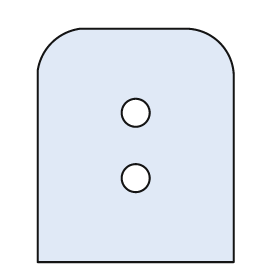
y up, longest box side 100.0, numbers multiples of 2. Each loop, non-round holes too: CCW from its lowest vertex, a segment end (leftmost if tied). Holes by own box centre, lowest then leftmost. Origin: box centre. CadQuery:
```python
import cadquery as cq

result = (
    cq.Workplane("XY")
    .moveTo(-42.0, -50.0)
    .lineTo(42.0, -50.0)
    .lineTo(42.0, 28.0)
    .threePointArc((36.0, 44.0), (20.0, 50.0))
    .lineTo(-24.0, 50.0)
    .threePointArc((-36.0, 44.0), (-42.0, 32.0))
    .close()
    .moveTo(0.0, -14.0)
    .circle(6.0)
    .moveTo(0.0, 14.0)
    .circle(6.0)
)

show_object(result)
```